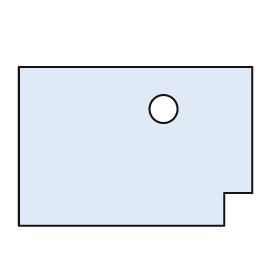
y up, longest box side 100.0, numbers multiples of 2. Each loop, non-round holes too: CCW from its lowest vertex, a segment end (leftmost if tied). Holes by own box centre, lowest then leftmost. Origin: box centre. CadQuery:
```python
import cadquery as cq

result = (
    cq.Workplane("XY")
    .moveTo(-50.0, -34.0)
    .lineTo(38.0, -34.0)
    .lineTo(38.0, -20.0)
    .lineTo(50.0, -20.0)
    .lineTo(50.0, 34.0)
    .lineTo(-50.0, 34.0)
    .close()
    .moveTo(12.0, 16.0)
    .circle(6.0)
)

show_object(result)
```